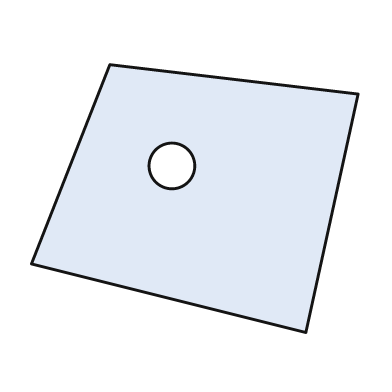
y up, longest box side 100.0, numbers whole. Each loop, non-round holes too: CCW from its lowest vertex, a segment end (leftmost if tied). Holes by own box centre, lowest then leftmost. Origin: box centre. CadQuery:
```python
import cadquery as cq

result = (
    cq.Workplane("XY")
    .moveTo(34.0, -41.0)
    .lineTo(50.0, 32.0)
    .lineTo(-26.0, 41.0)
    .lineTo(-50.0, -20.0)
    .close()
    .moveTo(-7.0, 10.0)
    .circle(7.0)
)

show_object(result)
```